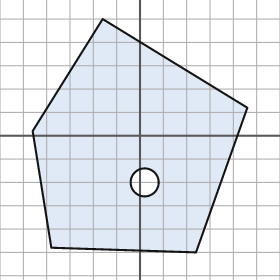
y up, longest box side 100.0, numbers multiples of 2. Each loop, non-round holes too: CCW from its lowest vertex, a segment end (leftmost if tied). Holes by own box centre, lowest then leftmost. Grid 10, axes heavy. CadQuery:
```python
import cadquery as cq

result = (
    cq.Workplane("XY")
    .moveTo(24.0, -50.0)
    .lineTo(46.0, 12.0)
    .lineTo(-16.0, 50.0)
    .lineTo(-46.0, 2.0)
    .lineTo(-38.0, -48.0)
    .close()
    .moveTo(2.0, -20.0)
    .circle(6.0)
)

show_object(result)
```